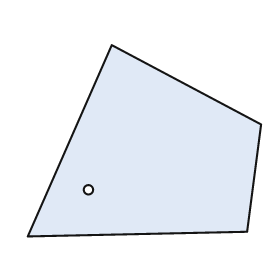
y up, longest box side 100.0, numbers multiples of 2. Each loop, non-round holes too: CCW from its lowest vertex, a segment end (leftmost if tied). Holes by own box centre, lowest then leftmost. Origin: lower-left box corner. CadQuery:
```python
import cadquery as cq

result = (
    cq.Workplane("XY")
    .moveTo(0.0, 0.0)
    .lineTo(94.0, 2.0)
    .lineTo(100.0, 48.0)
    .lineTo(36.0, 82.0)
    .close()
    .moveTo(26.0, 20.0)
    .circle(2.0)
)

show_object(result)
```